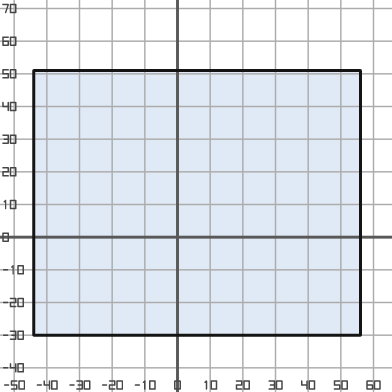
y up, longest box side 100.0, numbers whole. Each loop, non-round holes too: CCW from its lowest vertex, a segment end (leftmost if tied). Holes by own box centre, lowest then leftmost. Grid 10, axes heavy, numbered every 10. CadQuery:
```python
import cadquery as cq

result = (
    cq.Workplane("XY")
    .moveTo(-44.0, -30.0)
    .lineTo(56.0, -30.0)
    .lineTo(56.0, 51.0)
    .lineTo(-44.0, 51.0)
    .close()
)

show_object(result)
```